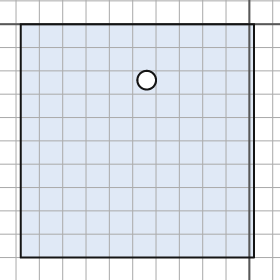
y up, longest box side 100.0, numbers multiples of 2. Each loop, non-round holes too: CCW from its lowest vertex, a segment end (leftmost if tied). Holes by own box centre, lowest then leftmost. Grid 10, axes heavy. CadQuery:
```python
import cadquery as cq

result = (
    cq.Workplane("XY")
    .moveTo(-98.0, -100.0)
    .lineTo(2.0, -100.0)
    .lineTo(2.0, 0.0)
    .lineTo(-98.0, 0.0)
    .close()
    .moveTo(-44.0, -24.0)
    .circle(4.0)
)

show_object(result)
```